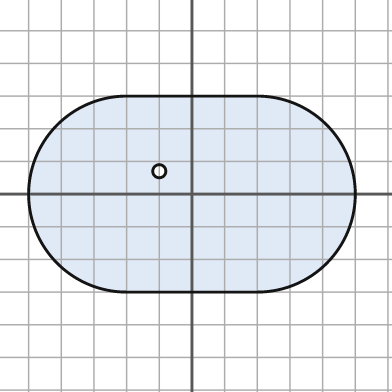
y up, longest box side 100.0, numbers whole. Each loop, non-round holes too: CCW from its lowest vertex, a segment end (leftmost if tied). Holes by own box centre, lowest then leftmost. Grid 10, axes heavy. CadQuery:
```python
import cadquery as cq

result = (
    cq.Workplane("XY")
    .moveTo(-20.0, -30.0)
    .lineTo(20.0, -30.0)
    .threePointArc((50.0, 0.0), (20.0, 30.0))
    .lineTo(-20.0, 30.0)
    .threePointArc((-50.0, 0.0), (-20.0, -30.0))
    .close()
    .moveTo(-10.0, 7.0)
    .circle(2.0)
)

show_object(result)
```